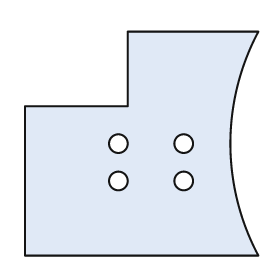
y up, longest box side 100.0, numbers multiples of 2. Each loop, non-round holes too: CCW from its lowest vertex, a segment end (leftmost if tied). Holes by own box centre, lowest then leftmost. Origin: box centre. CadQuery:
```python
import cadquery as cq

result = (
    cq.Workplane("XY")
    .moveTo(-50.0, -48.0)
    .lineTo(50.0, -48.0)
    .threePointArc((38.0, 0.0), (50.0, 48.0))
    .lineTo(-6.0, 48.0)
    .lineTo(-6.0, 16.0)
    .lineTo(-50.0, 16.0)
    .close()
    .moveTo(-10.0, -16.0)
    .circle(4.0)
    .moveTo(18.0, -16.0)
    .circle(4.0)
    .moveTo(-10.0, 0.0)
    .circle(4.0)
    .moveTo(18.0, 0.0)
    .circle(4.0)
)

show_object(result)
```